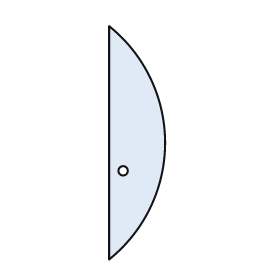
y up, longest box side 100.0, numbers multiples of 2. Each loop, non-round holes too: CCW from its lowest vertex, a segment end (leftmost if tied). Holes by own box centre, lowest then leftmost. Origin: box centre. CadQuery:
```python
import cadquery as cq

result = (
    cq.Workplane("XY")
    .moveTo(-12.0, -50.0)
    .threePointArc((12.0, 0.0), (-12.0, 50.0))
    .close()
    .moveTo(-6.0, -12.0)
    .circle(2.0)
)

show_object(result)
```